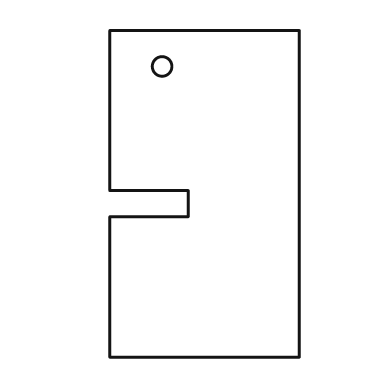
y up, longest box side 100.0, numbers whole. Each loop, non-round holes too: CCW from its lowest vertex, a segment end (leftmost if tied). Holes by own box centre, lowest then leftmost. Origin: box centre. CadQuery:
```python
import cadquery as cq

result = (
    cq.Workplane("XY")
    .moveTo(-29.0, -50.0)
    .lineTo(29.0, -50.0)
    .lineTo(29.0, 50.0)
    .lineTo(-29.0, 50.0)
    .lineTo(-29.0, 1.0)
    .lineTo(-5.0, 1.0)
    .lineTo(-5.0, -7.0)
    .lineTo(-29.0, -7.0)
    .close()
    .moveTo(-13.0, 39.0)
    .circle(3.0)
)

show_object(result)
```